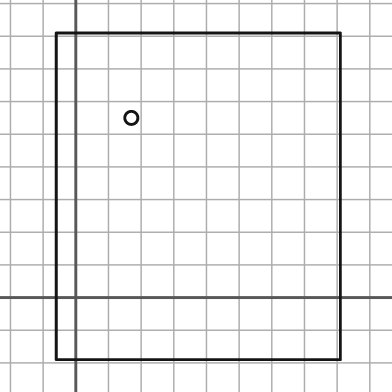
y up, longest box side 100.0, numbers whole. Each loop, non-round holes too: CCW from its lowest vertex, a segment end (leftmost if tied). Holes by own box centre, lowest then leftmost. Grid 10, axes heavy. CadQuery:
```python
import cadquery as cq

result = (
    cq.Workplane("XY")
    .moveTo(-6.0, -19.0)
    .lineTo(81.0, -19.0)
    .lineTo(81.0, 81.0)
    .lineTo(-6.0, 81.0)
    .close()
    .moveTo(17.0, 55.0)
    .circle(2.0)
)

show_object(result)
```